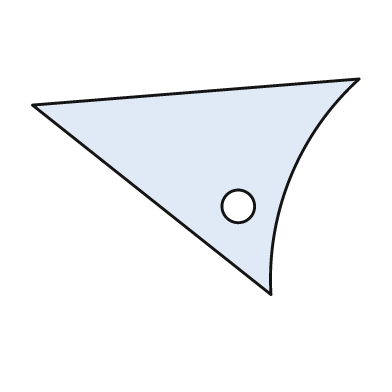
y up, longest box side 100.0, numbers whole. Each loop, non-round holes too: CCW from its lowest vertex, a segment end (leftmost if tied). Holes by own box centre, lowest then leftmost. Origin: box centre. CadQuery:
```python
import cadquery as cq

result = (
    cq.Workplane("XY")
    .moveTo(23.0, -33.0)
    .threePointArc((29.0, 3.0), (50.0, 33.0))
    .lineTo(-50.0, 25.0)
    .close()
    .moveTo(13.0, -6.0)
    .circle(5.0)
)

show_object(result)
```